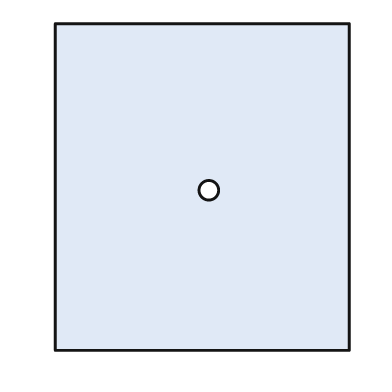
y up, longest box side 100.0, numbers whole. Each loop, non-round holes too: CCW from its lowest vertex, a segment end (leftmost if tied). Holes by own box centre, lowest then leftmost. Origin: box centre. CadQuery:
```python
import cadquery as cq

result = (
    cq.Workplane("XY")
    .moveTo(-45.0, -50.0)
    .lineTo(45.0, -50.0)
    .lineTo(45.0, 50.0)
    .lineTo(-45.0, 50.0)
    .close()
    .moveTo(2.0, -1.0)
    .circle(3.0)
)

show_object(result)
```